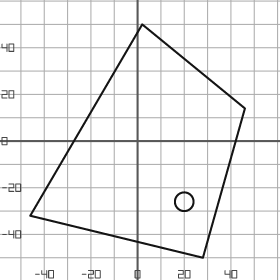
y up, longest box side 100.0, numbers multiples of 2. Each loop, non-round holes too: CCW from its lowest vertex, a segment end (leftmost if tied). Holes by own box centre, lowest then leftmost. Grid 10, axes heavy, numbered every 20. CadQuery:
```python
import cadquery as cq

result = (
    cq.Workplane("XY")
    .moveTo(28.0, -50.0)
    .lineTo(46.0, 14.0)
    .lineTo(2.0, 50.0)
    .lineTo(-46.0, -32.0)
    .close()
    .moveTo(20.0, -26.0)
    .circle(4.0)
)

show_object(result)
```